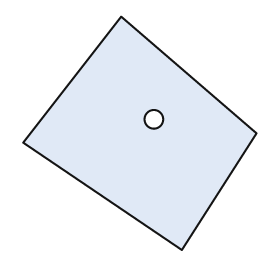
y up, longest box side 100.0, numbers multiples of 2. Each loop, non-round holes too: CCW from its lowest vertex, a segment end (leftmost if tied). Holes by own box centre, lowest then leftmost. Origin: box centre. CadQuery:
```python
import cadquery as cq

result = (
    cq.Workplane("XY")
    .moveTo(18.0, -50.0)
    .lineTo(50.0, 0.0)
    .lineTo(-8.0, 50.0)
    .lineTo(-50.0, -4.0)
    .close()
    .moveTo(6.0, 6.0)
    .circle(4.0)
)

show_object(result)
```